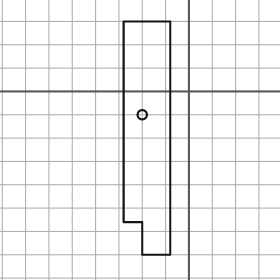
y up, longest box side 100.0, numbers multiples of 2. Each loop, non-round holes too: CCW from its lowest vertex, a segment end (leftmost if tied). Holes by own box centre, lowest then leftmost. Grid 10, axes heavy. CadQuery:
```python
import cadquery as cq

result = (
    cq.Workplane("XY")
    .moveTo(-20.0, -70.0)
    .lineTo(-8.0, -70.0)
    .lineTo(-8.0, 30.0)
    .lineTo(-28.0, 30.0)
    .lineTo(-28.0, -56.0)
    .lineTo(-20.0, -56.0)
    .close()
    .moveTo(-20.0, -10.0)
    .circle(2.0)
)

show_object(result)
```